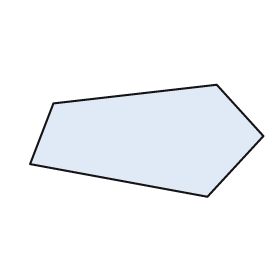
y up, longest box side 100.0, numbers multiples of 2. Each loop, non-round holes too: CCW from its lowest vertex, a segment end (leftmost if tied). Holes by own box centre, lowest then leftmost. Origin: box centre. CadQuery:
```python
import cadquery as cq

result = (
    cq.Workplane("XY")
    .moveTo(26.0, -24.0)
    .lineTo(50.0, 2.0)
    .lineTo(30.0, 24.0)
    .lineTo(-40.0, 16.0)
    .lineTo(-50.0, -10.0)
    .close()
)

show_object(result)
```